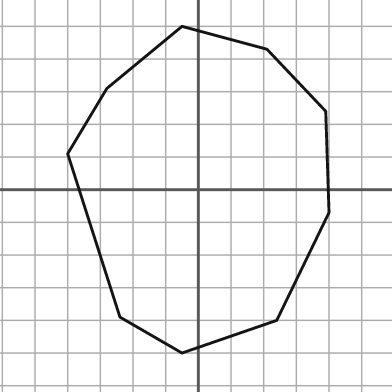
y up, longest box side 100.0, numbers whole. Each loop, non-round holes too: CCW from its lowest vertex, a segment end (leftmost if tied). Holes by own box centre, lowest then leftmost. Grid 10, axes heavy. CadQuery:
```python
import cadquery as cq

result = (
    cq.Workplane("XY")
    .moveTo(-5.0, -50.0)
    .lineTo(24.0, -40.0)
    .lineTo(40.0, -7.0)
    .lineTo(39.0, 24.0)
    .lineTo(21.0, 43.0)
    .lineTo(-5.0, 50.0)
    .lineTo(-28.0, 31.0)
    .lineTo(-40.0, 11.0)
    .lineTo(-24.0, -39.0)
    .close()
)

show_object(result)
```